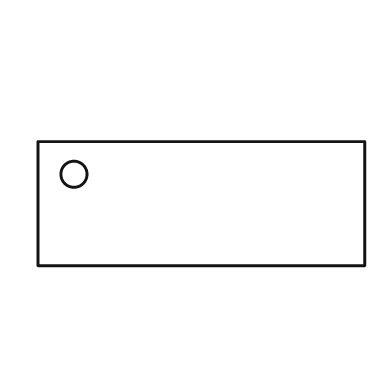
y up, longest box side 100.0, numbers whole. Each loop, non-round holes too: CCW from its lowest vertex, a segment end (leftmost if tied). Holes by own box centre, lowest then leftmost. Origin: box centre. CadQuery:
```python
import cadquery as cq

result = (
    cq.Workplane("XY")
    .moveTo(-50.0, -19.0)
    .lineTo(50.0, -19.0)
    .lineTo(50.0, 19.0)
    .lineTo(-50.0, 19.0)
    .close()
    .moveTo(-39.0, 9.0)
    .circle(4.0)
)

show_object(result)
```